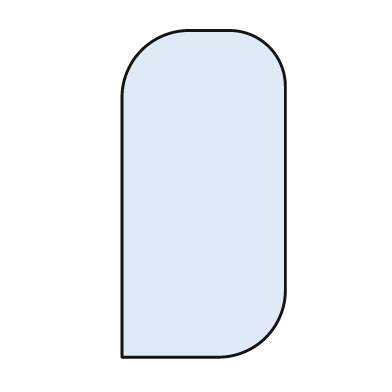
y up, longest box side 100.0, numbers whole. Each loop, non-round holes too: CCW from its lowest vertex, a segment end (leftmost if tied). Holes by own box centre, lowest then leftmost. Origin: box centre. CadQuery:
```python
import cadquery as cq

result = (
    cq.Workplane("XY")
    .moveTo(-25.0, -50.0)
    .lineTo(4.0, -50.0)
    .threePointArc((19.0, -44.0), (25.0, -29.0))
    .lineTo(25.0, 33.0)
    .threePointArc((20.0, 45.0), (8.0, 50.0))
    .lineTo(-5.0, 50.0)
    .threePointArc((-19.0, 44.0), (-25.0, 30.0))
    .close()
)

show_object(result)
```